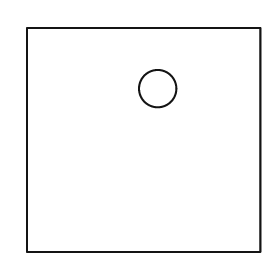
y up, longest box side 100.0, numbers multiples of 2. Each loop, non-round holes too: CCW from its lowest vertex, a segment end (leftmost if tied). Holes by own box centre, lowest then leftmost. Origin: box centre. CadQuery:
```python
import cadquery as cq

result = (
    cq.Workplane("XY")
    .moveTo(-50.0, -48.0)
    .lineTo(50.0, -48.0)
    .lineTo(50.0, 48.0)
    .lineTo(-50.0, 48.0)
    .close()
    .moveTo(6.0, 22.0)
    .circle(8.0)
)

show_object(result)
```